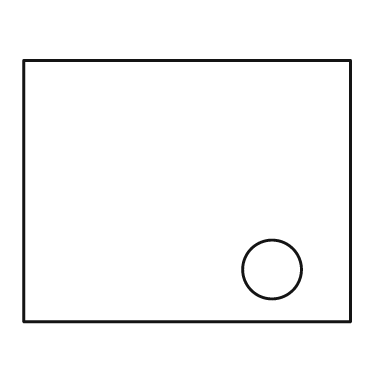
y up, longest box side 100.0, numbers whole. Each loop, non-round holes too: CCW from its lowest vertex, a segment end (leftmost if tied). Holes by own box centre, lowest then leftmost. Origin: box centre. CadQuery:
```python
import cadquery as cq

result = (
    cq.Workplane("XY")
    .moveTo(-50.0, -40.0)
    .lineTo(50.0, -40.0)
    .lineTo(50.0, 40.0)
    .lineTo(-50.0, 40.0)
    .close()
    .moveTo(26.0, -24.0)
    .circle(9.0)
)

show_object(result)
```